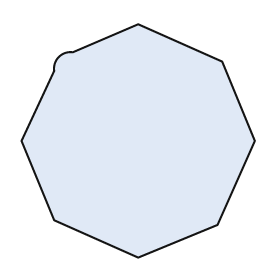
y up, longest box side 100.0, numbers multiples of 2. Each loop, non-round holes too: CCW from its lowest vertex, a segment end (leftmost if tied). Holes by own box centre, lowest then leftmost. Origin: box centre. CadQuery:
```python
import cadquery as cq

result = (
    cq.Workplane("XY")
    .moveTo(0.0, -50.0)
    .lineTo(34.0, -36.0)
    .lineTo(50.0, 0.0)
    .lineTo(36.0, 34.0)
    .lineTo(0.0, 50.0)
    .lineTo(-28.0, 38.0)
    .threePointArc((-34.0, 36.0), (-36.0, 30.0))
    .lineTo(-50.0, 0.0)
    .lineTo(-36.0, -34.0)
    .close()
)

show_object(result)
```